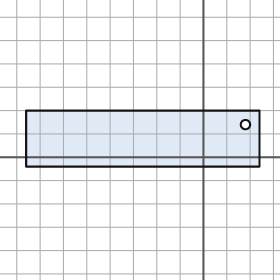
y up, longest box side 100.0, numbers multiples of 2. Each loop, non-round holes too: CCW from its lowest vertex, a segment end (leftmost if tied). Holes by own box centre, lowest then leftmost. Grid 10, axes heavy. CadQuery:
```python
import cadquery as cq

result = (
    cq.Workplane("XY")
    .moveTo(-76.0, -4.0)
    .lineTo(24.0, -4.0)
    .lineTo(24.0, 20.0)
    .lineTo(-76.0, 20.0)
    .close()
    .moveTo(18.0, 14.0)
    .circle(2.0)
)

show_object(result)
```